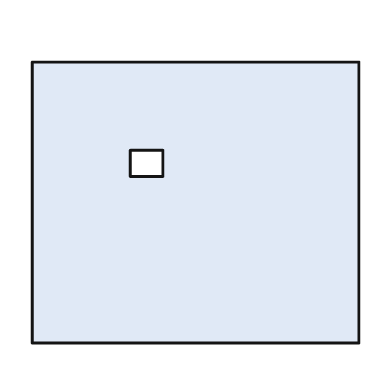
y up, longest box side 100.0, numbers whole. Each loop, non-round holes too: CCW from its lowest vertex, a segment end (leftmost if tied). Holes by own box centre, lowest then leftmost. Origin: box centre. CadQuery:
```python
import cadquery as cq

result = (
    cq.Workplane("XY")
    .moveTo(-50.0, -43.0)
    .lineTo(50.0, -43.0)
    .lineTo(50.0, 43.0)
    .lineTo(-50.0, 43.0)
    .close()
    .moveTo(-20.0, 8.0)
    .lineTo(-10.0, 8.0)
    .lineTo(-10.0, 16.0)
    .lineTo(-20.0, 16.0)
    .close()
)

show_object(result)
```